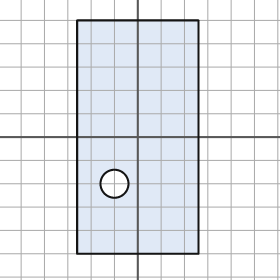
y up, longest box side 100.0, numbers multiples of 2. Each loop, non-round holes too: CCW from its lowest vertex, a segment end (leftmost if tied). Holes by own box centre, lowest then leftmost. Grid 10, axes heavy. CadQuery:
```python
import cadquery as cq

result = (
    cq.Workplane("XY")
    .moveTo(-26.0, -50.0)
    .lineTo(26.0, -50.0)
    .lineTo(26.0, 50.0)
    .lineTo(-26.0, 50.0)
    .close()
    .moveTo(-10.0, -20.0)
    .circle(6.0)
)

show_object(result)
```